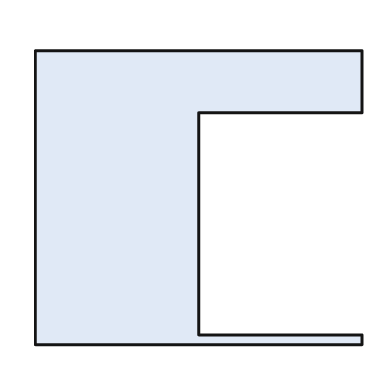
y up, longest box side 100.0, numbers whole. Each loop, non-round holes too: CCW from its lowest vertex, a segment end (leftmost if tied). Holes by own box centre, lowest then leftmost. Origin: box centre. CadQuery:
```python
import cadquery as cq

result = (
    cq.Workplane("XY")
    .moveTo(-50.0, -45.0)
    .lineTo(50.0, -45.0)
    .lineTo(50.0, -42.0)
    .lineTo(0.0, -42.0)
    .lineTo(0.0, 26.0)
    .lineTo(50.0, 26.0)
    .lineTo(50.0, 45.0)
    .lineTo(-50.0, 45.0)
    .close()
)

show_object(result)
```